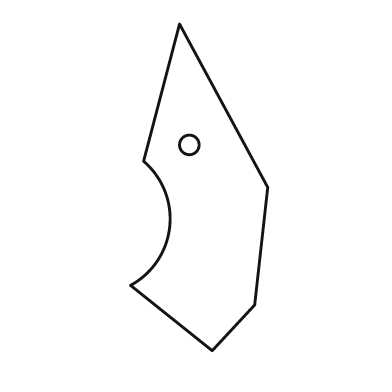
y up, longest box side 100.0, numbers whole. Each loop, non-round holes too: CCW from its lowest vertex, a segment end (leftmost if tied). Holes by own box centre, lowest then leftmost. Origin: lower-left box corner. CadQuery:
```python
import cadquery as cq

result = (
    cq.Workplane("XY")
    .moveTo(25.0, 0.0)
    .lineTo(38.0, 14.0)
    .lineTo(42.0, 50.0)
    .lineTo(15.0, 100.0)
    .lineTo(4.0, 58.0)
    .threePointArc((12.0, 38.0), (0.0, 20.0))
    .close()
    .moveTo(18.0, 63.0)
    .circle(3.0)
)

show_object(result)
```